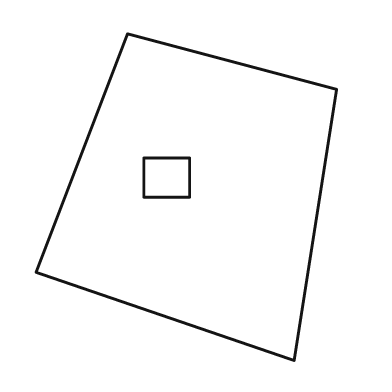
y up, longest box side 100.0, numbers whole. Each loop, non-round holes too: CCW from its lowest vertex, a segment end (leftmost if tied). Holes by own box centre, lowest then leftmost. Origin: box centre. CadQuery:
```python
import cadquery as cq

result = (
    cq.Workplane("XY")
    .moveTo(33.0, -50.0)
    .lineTo(46.0, 33.0)
    .lineTo(-18.0, 50.0)
    .lineTo(-46.0, -23.0)
    .close()
    .moveTo(-13.0, 0.0)
    .lineTo(1.0, 0.0)
    .lineTo(1.0, 12.0)
    .lineTo(-13.0, 12.0)
    .close()
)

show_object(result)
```